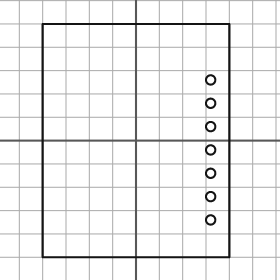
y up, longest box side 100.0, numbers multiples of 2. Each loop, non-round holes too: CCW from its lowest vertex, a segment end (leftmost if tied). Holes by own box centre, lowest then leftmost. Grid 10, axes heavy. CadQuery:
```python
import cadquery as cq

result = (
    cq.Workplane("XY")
    .moveTo(-40.0, -50.0)
    .lineTo(40.0, -50.0)
    .lineTo(40.0, 50.0)
    .lineTo(-40.0, 50.0)
    .close()
    .moveTo(32.0, -34.0)
    .circle(2.0)
    .moveTo(32.0, -24.0)
    .circle(2.0)
    .moveTo(32.0, -14.0)
    .circle(2.0)
    .moveTo(32.0, -4.0)
    .circle(2.0)
    .moveTo(32.0, 6.0)
    .circle(2.0)
    .moveTo(32.0, 16.0)
    .circle(2.0)
    .moveTo(32.0, 26.0)
    .circle(2.0)
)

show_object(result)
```